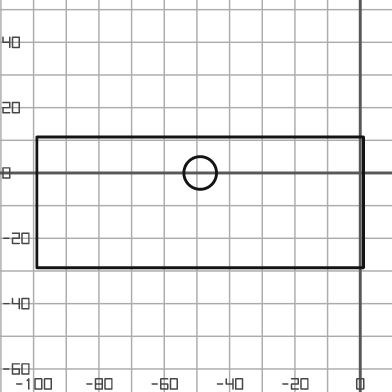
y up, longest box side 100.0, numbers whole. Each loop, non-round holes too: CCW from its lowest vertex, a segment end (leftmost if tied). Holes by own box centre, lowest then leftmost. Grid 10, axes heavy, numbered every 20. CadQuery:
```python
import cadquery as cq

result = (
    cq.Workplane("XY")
    .moveTo(-99.0, -29.0)
    .lineTo(1.0, -29.0)
    .lineTo(1.0, 11.0)
    .lineTo(-99.0, 11.0)
    .close()
    .moveTo(-49.0, 0.0)
    .circle(5.0)
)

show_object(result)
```